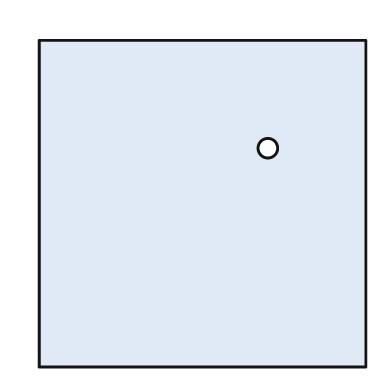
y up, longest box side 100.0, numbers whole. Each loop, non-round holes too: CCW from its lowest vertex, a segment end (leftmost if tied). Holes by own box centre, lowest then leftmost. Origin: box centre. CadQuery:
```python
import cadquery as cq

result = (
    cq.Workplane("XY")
    .moveTo(-50.0, -50.0)
    .lineTo(50.0, -50.0)
    .lineTo(50.0, 50.0)
    .lineTo(-50.0, 50.0)
    .close()
    .moveTo(20.0, 17.0)
    .circle(3.0)
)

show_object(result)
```